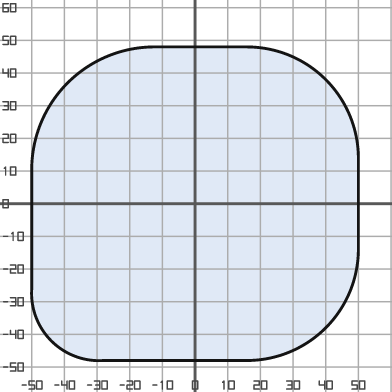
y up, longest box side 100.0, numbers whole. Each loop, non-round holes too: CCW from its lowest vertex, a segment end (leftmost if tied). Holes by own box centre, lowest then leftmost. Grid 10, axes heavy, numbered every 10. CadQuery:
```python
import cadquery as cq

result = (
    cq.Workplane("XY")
    .moveTo(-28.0, -48.0)
    .lineTo(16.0, -48.0)
    .threePointArc((40.0, -38.0), (50.0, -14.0))
    .lineTo(50.0, 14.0)
    .threePointArc((40.0, 38.0), (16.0, 48.0))
    .lineTo(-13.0, 48.0)
    .threePointArc((-39.0, 37.0), (-50.0, 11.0))
    .lineTo(-50.0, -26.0)
    .threePointArc((-44.0, -42.0), (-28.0, -48.0))
    .close()
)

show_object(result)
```